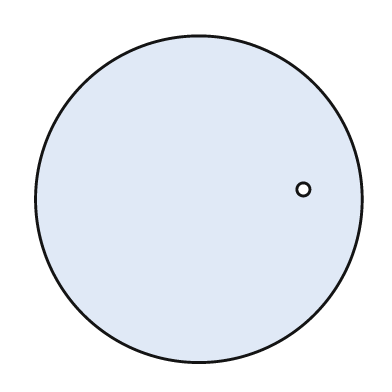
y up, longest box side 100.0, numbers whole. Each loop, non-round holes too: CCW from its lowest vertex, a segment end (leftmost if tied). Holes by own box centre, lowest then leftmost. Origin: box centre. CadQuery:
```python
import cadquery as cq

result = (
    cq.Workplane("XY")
    .moveTo(0.0, 0.0)
    .circle(50.0)
    .moveTo(32.0, 3.0)
    .circle(2.0)
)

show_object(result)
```